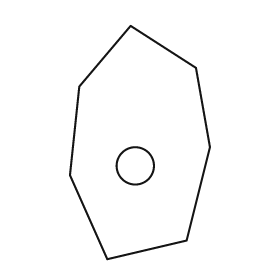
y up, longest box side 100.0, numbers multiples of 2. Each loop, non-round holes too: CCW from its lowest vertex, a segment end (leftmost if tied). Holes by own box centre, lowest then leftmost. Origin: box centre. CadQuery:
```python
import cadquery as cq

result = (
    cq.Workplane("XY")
    .moveTo(-14.0, -50.0)
    .lineTo(20.0, -42.0)
    .lineTo(30.0, -2.0)
    .lineTo(24.0, 32.0)
    .lineTo(-4.0, 50.0)
    .lineTo(-26.0, 24.0)
    .lineTo(-30.0, -14.0)
    .close()
    .moveTo(-2.0, -10.0)
    .circle(8.0)
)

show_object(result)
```